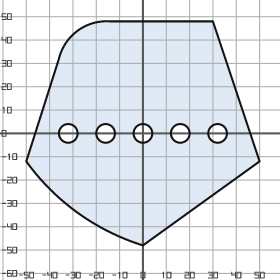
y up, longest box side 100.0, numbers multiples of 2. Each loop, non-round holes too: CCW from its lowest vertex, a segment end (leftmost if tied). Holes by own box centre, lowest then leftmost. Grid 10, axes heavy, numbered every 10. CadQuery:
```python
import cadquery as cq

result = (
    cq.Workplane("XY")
    .moveTo(0.0, -48.0)
    .lineTo(50.0, -12.0)
    .lineTo(30.0, 48.0)
    .lineTo(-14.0, 48.0)
    .threePointArc((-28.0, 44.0), (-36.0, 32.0))
    .lineTo(-50.0, -12.0)
    .threePointArc((-28.0, -34.0), (0.0, -48.0))
    .close()
    .moveTo(-32.0, 0.0)
    .circle(4.0)
    .moveTo(-16.0, 0.0)
    .circle(4.0)
    .moveTo(0.0, 0.0)
    .circle(4.0)
    .moveTo(16.0, 0.0)
    .circle(4.0)
    .moveTo(32.0, 0.0)
    .circle(4.0)
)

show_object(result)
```